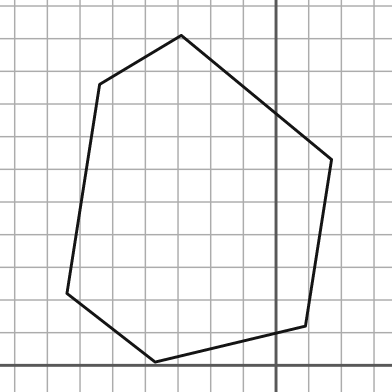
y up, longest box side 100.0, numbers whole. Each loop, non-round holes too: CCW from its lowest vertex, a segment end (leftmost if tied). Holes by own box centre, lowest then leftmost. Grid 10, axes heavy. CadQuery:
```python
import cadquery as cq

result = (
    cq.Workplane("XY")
    .moveTo(-37.0, 1.0)
    .lineTo(9.0, 12.0)
    .lineTo(17.0, 63.0)
    .lineTo(-29.0, 101.0)
    .lineTo(-54.0, 86.0)
    .lineTo(-64.0, 22.0)
    .close()
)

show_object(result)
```